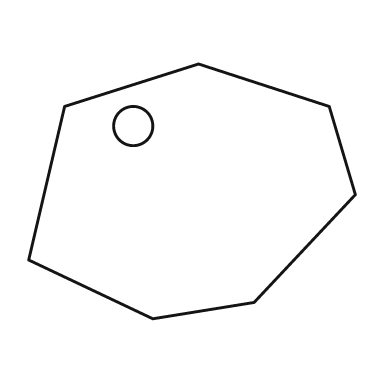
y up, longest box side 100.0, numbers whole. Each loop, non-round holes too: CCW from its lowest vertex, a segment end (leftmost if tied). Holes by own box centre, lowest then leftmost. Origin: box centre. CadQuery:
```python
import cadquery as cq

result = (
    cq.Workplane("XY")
    .moveTo(-12.0, -39.0)
    .lineTo(19.0, -34.0)
    .lineTo(50.0, -1.0)
    .lineTo(42.0, 26.0)
    .lineTo(2.0, 39.0)
    .lineTo(-39.0, 26.0)
    .lineTo(-50.0, -21.0)
    .close()
    .moveTo(-18.0, 20.0)
    .circle(6.0)
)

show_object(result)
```